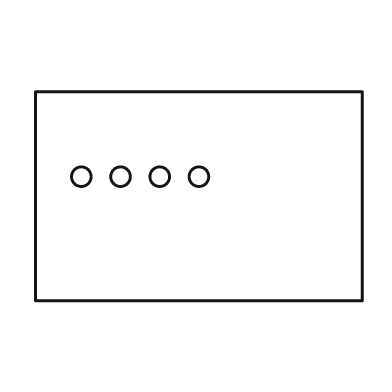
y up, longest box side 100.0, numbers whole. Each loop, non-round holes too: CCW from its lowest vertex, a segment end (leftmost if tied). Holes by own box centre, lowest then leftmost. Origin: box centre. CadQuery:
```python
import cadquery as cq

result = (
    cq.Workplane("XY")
    .moveTo(-50.0, -32.0)
    .lineTo(50.0, -32.0)
    .lineTo(50.0, 32.0)
    .lineTo(-50.0, 32.0)
    .close()
    .moveTo(-36.0, 6.0)
    .circle(3.0)
    .moveTo(-24.0, 6.0)
    .circle(3.0)
    .moveTo(-12.0, 6.0)
    .circle(3.0)
    .moveTo(0.0, 6.0)
    .circle(3.0)
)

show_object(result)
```